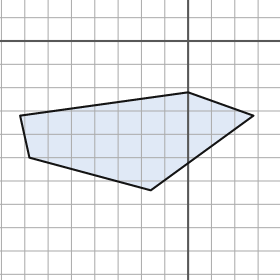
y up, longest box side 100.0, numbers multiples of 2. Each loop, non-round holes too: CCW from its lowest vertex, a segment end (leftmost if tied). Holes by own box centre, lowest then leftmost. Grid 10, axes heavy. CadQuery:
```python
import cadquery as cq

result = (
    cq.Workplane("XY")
    .moveTo(-16.0, -64.0)
    .lineTo(28.0, -32.0)
    .lineTo(0.0, -22.0)
    .lineTo(-72.0, -32.0)
    .lineTo(-68.0, -50.0)
    .close()
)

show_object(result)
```